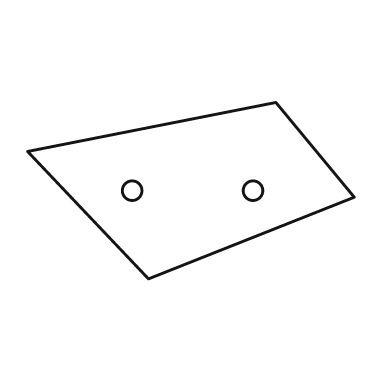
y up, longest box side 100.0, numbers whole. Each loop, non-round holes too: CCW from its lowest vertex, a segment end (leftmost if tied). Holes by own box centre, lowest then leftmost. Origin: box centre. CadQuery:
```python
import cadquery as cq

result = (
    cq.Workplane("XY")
    .moveTo(-13.0, -27.0)
    .lineTo(50.0, -2.0)
    .lineTo(26.0, 27.0)
    .lineTo(-50.0, 12.0)
    .close()
    .moveTo(-18.0, 0.0)
    .circle(3.0)
    .moveTo(19.0, 0.0)
    .circle(3.0)
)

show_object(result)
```